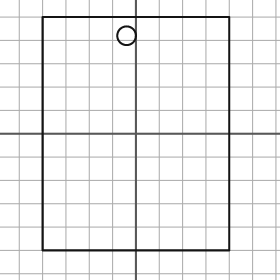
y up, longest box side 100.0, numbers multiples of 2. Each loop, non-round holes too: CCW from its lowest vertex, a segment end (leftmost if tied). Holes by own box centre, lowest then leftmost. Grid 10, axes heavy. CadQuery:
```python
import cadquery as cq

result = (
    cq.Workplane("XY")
    .moveTo(-40.0, -50.0)
    .lineTo(40.0, -50.0)
    .lineTo(40.0, 50.0)
    .lineTo(-40.0, 50.0)
    .close()
    .moveTo(-4.0, 42.0)
    .circle(4.0)
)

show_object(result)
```